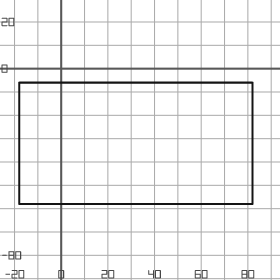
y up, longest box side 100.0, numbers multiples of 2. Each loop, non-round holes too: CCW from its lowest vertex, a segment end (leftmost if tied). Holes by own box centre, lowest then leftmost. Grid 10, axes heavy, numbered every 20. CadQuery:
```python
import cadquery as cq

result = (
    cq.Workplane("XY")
    .moveTo(-18.0, -58.0)
    .lineTo(82.0, -58.0)
    .lineTo(82.0, -6.0)
    .lineTo(-18.0, -6.0)
    .close()
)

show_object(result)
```